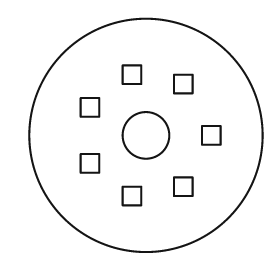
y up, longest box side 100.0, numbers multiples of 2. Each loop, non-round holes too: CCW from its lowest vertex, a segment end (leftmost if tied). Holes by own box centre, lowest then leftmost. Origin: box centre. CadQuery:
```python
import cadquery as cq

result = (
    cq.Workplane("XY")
    .moveTo(0.0, 0.0)
    .circle(50.0)
    .moveTo(-10.0, -30.0)
    .lineTo(-2.0, -30.0)
    .lineTo(-2.0, -22.0)
    .lineTo(-10.0, -22.0)
    .close()
    .moveTo(12.0, -26.0)
    .lineTo(20.0, -26.0)
    .lineTo(20.0, -18.0)
    .lineTo(12.0, -18.0)
    .close()
    .moveTo(-28.0, -16.0)
    .lineTo(-20.0, -16.0)
    .lineTo(-20.0, -8.0)
    .lineTo(-28.0, -8.0)
    .close()
    .moveTo(0.0, 0.0)
    .circle(10.0)
    .moveTo(24.0, -4.0)
    .lineTo(32.0, -4.0)
    .lineTo(32.0, 4.0)
    .lineTo(24.0, 4.0)
    .close()
    .moveTo(-28.0, 8.0)
    .lineTo(-20.0, 8.0)
    .lineTo(-20.0, 16.0)
    .lineTo(-28.0, 16.0)
    .close()
    .moveTo(12.0, 18.0)
    .lineTo(20.0, 18.0)
    .lineTo(20.0, 26.0)
    .lineTo(12.0, 26.0)
    .close()
    .moveTo(-10.0, 22.0)
    .lineTo(-2.0, 22.0)
    .lineTo(-2.0, 30.0)
    .lineTo(-10.0, 30.0)
    .close()
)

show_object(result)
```